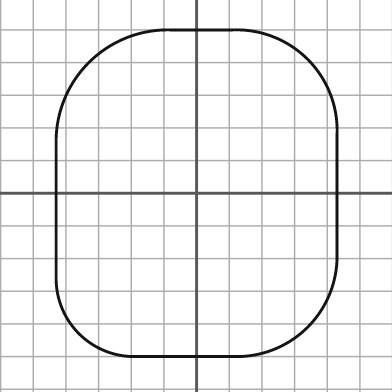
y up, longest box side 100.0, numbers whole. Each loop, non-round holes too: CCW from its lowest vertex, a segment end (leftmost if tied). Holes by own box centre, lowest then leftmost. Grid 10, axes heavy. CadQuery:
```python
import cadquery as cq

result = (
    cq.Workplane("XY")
    .moveTo(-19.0, -50.0)
    .lineTo(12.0, -50.0)
    .threePointArc((34.0, -41.0), (43.0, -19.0))
    .lineTo(43.0, 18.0)
    .threePointArc((34.0, 41.0), (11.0, 50.0))
    .lineTo(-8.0, 50.0)
    .threePointArc((-33.0, 40.0), (-43.0, 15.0))
    .lineTo(-43.0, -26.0)
    .threePointArc((-36.0, -43.0), (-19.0, -50.0))
    .close()
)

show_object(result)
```